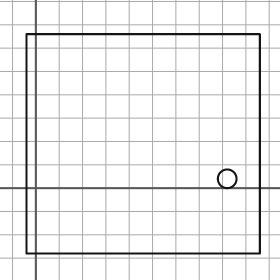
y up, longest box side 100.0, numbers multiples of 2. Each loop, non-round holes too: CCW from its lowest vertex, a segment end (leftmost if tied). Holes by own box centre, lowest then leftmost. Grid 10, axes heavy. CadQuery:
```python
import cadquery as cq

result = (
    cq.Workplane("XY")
    .moveTo(-4.0, -28.0)
    .lineTo(96.0, -28.0)
    .lineTo(96.0, 66.0)
    .lineTo(-4.0, 66.0)
    .close()
    .moveTo(82.0, 4.0)
    .circle(4.0)
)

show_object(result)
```